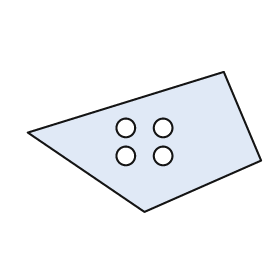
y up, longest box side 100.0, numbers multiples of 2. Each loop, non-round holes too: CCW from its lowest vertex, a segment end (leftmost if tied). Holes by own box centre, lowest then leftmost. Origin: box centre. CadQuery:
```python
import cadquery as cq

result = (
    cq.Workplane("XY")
    .moveTo(0.0, -30.0)
    .lineTo(50.0, -8.0)
    .lineTo(34.0, 30.0)
    .lineTo(-50.0, 4.0)
    .close()
    .moveTo(-8.0, -6.0)
    .circle(4.0)
    .moveTo(8.0, -6.0)
    .circle(4.0)
    .moveTo(-8.0, 6.0)
    .circle(4.0)
    .moveTo(8.0, 6.0)
    .circle(4.0)
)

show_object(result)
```